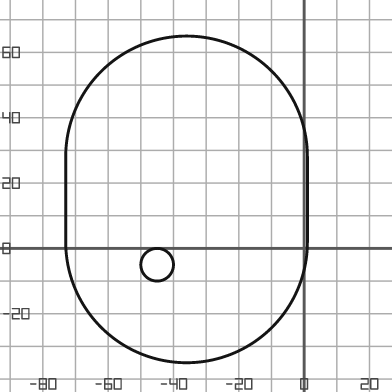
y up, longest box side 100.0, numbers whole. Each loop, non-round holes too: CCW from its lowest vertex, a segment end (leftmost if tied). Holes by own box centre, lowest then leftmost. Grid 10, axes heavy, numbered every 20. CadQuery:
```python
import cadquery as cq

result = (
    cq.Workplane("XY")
    .moveTo(-73.0, 2.0)
    .threePointArc((-36.0, -35.0), (1.0, 2.0))
    .lineTo(1.0, 28.0)
    .threePointArc((-36.0, 65.0), (-73.0, 28.0))
    .close()
    .moveTo(-45.0, -5.0)
    .circle(5.0)
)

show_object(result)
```